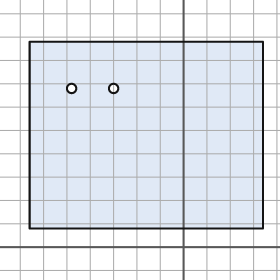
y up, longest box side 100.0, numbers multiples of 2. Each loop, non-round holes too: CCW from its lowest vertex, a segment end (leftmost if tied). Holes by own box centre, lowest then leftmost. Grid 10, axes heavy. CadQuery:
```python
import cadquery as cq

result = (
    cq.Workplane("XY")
    .moveTo(-66.0, 8.0)
    .lineTo(34.0, 8.0)
    .lineTo(34.0, 88.0)
    .lineTo(-66.0, 88.0)
    .close()
    .moveTo(-48.0, 68.0)
    .circle(2.0)
    .moveTo(-30.0, 68.0)
    .circle(2.0)
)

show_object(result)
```